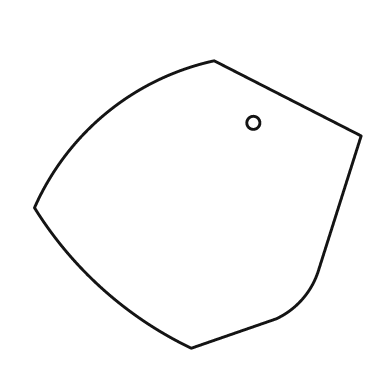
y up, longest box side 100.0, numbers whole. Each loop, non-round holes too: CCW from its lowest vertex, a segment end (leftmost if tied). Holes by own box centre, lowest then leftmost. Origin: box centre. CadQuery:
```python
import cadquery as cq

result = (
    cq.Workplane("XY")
    .moveTo(-2.0, -44.0)
    .lineTo(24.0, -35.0)
    .threePointArc((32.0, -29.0), (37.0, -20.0))
    .lineTo(50.0, 21.0)
    .lineTo(5.0, 44.0)
    .threePointArc((-28.0, 28.0), (-50.0, -1.0))
    .threePointArc((-29.0, -26.0), (-2.0, -44.0))
    .close()
    .moveTo(17.0, 25.0)
    .circle(2.0)
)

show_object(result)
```